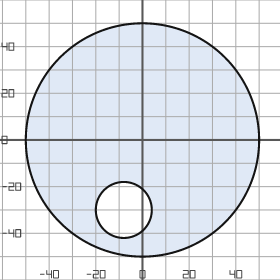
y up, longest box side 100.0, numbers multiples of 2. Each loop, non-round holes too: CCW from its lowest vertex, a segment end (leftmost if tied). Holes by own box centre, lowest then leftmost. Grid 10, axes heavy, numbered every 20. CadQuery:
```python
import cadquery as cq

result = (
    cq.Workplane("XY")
    .moveTo(0.0, 0.0)
    .circle(50.0)
    .moveTo(-8.0, -30.0)
    .circle(12.0)
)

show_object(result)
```